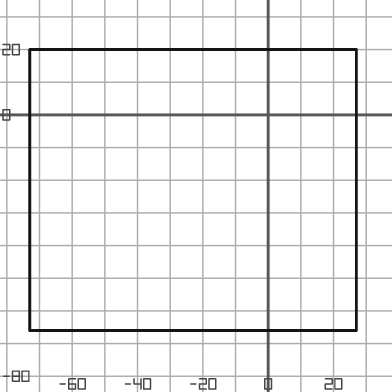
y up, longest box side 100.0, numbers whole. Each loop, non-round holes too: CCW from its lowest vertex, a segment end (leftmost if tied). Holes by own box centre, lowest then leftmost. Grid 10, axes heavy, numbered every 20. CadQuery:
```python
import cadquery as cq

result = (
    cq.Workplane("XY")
    .moveTo(-73.0, -66.0)
    .lineTo(27.0, -66.0)
    .lineTo(27.0, 20.0)
    .lineTo(-73.0, 20.0)
    .close()
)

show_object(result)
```